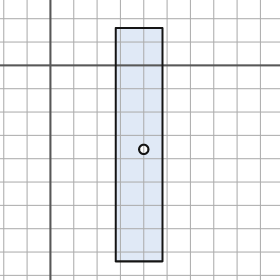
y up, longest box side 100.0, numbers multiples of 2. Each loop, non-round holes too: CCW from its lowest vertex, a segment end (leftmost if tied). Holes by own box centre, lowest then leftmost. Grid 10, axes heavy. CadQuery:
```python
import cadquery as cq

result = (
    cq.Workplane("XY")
    .moveTo(28.0, -84.0)
    .lineTo(48.0, -84.0)
    .lineTo(48.0, 16.0)
    .lineTo(28.0, 16.0)
    .close()
    .moveTo(40.0, -36.0)
    .circle(2.0)
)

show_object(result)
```